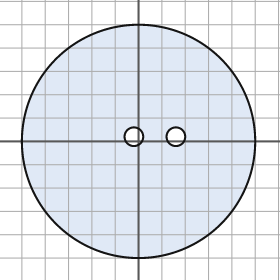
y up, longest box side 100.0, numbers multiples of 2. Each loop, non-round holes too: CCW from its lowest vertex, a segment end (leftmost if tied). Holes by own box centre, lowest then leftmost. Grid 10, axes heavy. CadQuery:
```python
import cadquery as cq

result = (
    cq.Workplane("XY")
    .moveTo(0.0, 0.0)
    .circle(50.0)
    .moveTo(-2.0, 2.0)
    .circle(4.0)
    .moveTo(16.0, 2.0)
    .circle(4.0)
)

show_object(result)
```